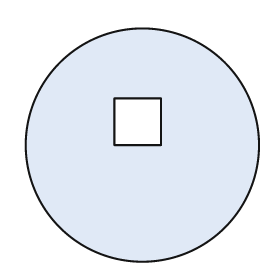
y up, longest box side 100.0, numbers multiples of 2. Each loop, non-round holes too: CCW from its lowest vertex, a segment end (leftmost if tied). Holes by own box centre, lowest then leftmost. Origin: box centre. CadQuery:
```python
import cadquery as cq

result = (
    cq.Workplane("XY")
    .moveTo(0.0, 0.0)
    .circle(50.0)
    .moveTo(-12.0, 0.0)
    .lineTo(8.0, 0.0)
    .lineTo(8.0, 20.0)
    .lineTo(-12.0, 20.0)
    .close()
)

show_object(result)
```